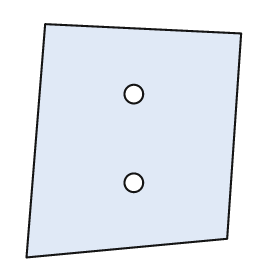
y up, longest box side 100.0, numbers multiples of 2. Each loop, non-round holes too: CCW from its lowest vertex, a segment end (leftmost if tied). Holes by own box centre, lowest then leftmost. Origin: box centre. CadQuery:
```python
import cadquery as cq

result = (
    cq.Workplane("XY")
    .moveTo(-46.0, -50.0)
    .lineTo(40.0, -42.0)
    .lineTo(46.0, 46.0)
    .lineTo(-38.0, 50.0)
    .close()
    .moveTo(0.0, -18.0)
    .circle(4.0)
    .moveTo(0.0, 20.0)
    .circle(4.0)
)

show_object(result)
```